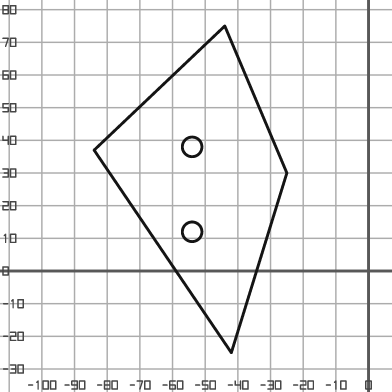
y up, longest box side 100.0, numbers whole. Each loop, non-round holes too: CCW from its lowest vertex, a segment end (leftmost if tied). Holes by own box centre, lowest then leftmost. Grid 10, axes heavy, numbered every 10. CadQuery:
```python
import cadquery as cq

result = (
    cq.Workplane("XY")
    .moveTo(-42.0, -25.0)
    .lineTo(-25.0, 30.0)
    .lineTo(-44.0, 75.0)
    .lineTo(-84.0, 37.0)
    .close()
    .moveTo(-54.0, 12.0)
    .circle(3.0)
    .moveTo(-54.0, 38.0)
    .circle(3.0)
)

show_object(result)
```